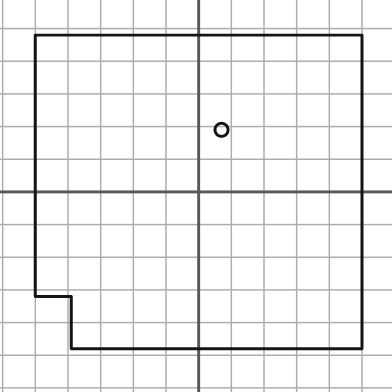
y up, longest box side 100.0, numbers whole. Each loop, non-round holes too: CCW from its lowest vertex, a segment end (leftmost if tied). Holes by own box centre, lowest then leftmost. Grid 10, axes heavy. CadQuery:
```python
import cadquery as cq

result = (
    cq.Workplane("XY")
    .moveTo(-39.0, -48.0)
    .lineTo(50.0, -48.0)
    .lineTo(50.0, 48.0)
    .lineTo(-50.0, 48.0)
    .lineTo(-50.0, -32.0)
    .lineTo(-39.0, -32.0)
    .close()
    .moveTo(7.0, 19.0)
    .circle(2.0)
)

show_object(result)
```